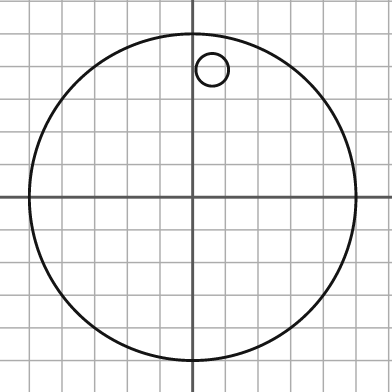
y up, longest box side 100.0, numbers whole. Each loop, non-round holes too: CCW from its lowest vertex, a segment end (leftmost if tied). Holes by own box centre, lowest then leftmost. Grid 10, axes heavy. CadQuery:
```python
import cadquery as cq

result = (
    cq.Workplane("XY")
    .moveTo(0.0, 0.0)
    .circle(50.0)
    .moveTo(6.0, 39.0)
    .circle(5.0)
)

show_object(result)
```